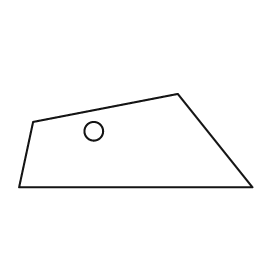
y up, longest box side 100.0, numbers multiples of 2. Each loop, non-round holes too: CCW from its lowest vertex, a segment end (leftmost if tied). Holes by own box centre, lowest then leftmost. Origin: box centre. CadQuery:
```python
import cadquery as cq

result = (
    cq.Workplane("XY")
    .moveTo(-50.0, -20.0)
    .lineTo(50.0, -20.0)
    .lineTo(18.0, 20.0)
    .lineTo(-44.0, 8.0)
    .close()
    .moveTo(-18.0, 4.0)
    .circle(4.0)
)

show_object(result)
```